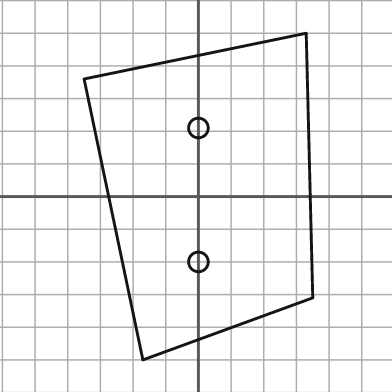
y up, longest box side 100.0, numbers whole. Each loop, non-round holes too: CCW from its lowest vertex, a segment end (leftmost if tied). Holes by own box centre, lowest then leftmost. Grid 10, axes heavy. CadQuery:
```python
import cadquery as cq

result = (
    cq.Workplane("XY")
    .moveTo(-17.0, -50.0)
    .lineTo(35.0, -31.0)
    .lineTo(33.0, 50.0)
    .lineTo(-35.0, 36.0)
    .close()
    .moveTo(0.0, -20.0)
    .circle(3.0)
    .moveTo(0.0, 21.0)
    .circle(3.0)
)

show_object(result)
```